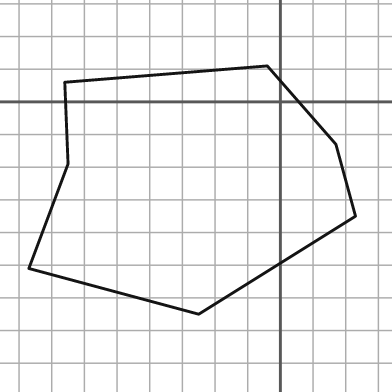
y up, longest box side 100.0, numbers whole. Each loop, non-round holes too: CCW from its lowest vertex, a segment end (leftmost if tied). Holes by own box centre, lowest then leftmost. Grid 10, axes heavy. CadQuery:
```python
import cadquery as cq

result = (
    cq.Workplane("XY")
    .moveTo(-25.0, -65.0)
    .lineTo(23.0, -35.0)
    .lineTo(17.0, -13.0)
    .lineTo(-4.0, 11.0)
    .lineTo(-66.0, 6.0)
    .lineTo(-65.0, -19.0)
    .lineTo(-77.0, -51.0)
    .close()
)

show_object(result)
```